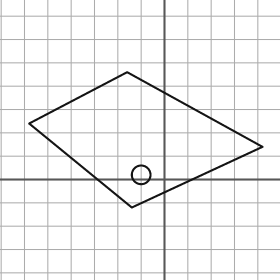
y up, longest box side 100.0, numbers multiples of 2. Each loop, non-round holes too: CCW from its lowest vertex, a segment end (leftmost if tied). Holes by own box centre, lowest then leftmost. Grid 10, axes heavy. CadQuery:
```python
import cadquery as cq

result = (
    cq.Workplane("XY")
    .moveTo(-14.0, -12.0)
    .lineTo(42.0, 14.0)
    .lineTo(-16.0, 46.0)
    .lineTo(-58.0, 24.0)
    .close()
    .moveTo(-10.0, 2.0)
    .circle(4.0)
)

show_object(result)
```